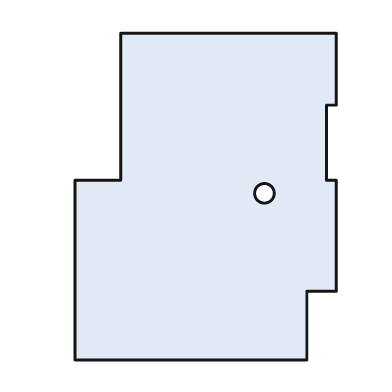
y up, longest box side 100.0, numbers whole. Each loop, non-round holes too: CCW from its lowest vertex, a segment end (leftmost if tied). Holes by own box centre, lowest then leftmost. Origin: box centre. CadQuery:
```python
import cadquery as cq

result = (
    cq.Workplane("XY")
    .moveTo(-40.0, -50.0)
    .lineTo(31.0, -50.0)
    .lineTo(31.0, -29.0)
    .lineTo(40.0, -29.0)
    .lineTo(40.0, 5.0)
    .lineTo(37.0, 5.0)
    .lineTo(37.0, 28.0)
    .lineTo(40.0, 28.0)
    .lineTo(40.0, 50.0)
    .lineTo(-26.0, 50.0)
    .lineTo(-26.0, 5.0)
    .lineTo(-40.0, 5.0)
    .close()
    .moveTo(18.0, 1.0)
    .circle(3.0)
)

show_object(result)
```